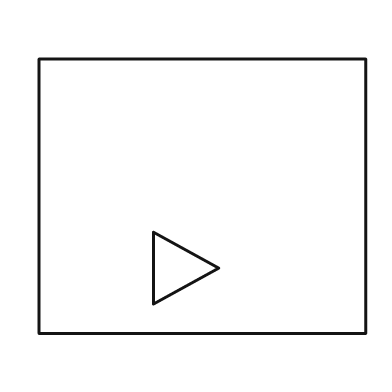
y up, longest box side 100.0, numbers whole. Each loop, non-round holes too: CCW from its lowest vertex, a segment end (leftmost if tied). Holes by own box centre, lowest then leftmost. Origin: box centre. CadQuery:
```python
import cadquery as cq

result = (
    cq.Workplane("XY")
    .moveTo(-50.0, -42.0)
    .lineTo(50.0, -42.0)
    .lineTo(50.0, 42.0)
    .lineTo(-50.0, 42.0)
    .close()
    .moveTo(-15.0, -33.0)
    .lineTo(5.0, -22.0)
    .lineTo(-15.0, -11.0)
    .close()
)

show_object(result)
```